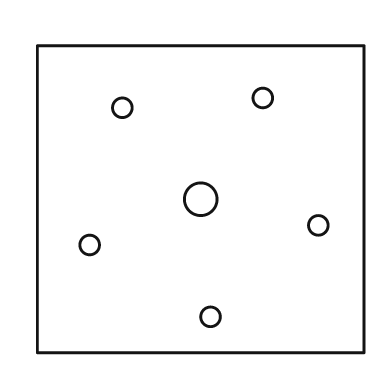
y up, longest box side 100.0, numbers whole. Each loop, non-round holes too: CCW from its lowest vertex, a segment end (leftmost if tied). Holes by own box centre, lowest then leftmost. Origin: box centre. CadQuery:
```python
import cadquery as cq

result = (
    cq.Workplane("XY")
    .moveTo(-50.0, -47.0)
    .lineTo(50.0, -47.0)
    .lineTo(50.0, 47.0)
    .lineTo(-50.0, 47.0)
    .close()
    .moveTo(3.0, -36.0)
    .circle(3.0)
    .moveTo(-34.0, -14.0)
    .circle(3.0)
    .moveTo(36.0, -8.0)
    .circle(3.0)
    .moveTo(0.0, 0.0)
    .circle(5.0)
    .moveTo(-24.0, 28.0)
    .circle(3.0)
    .moveTo(19.0, 31.0)
    .circle(3.0)
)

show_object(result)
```